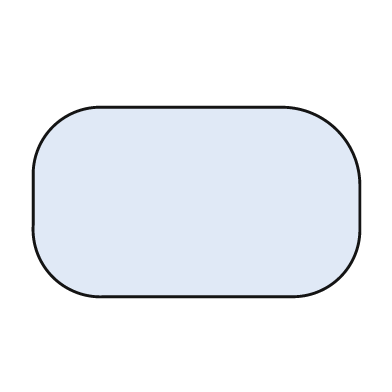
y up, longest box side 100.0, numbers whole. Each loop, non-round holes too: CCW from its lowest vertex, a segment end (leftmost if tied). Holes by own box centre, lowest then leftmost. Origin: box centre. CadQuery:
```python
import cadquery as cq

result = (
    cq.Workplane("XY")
    .moveTo(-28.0, -29.0)
    .lineTo(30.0, -29.0)
    .threePointArc((44.0, -23.0), (50.0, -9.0))
    .lineTo(50.0, 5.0)
    .threePointArc((43.0, 22.0), (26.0, 29.0))
    .lineTo(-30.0, 29.0)
    .threePointArc((-44.0, 23.0), (-50.0, 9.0))
    .lineTo(-50.0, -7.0)
    .threePointArc((-44.0, -23.0), (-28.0, -29.0))
    .close()
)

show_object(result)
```